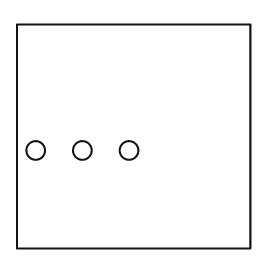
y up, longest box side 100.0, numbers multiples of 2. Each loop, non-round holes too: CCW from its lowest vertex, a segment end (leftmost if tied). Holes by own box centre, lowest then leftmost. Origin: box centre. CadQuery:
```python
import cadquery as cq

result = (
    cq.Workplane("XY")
    .moveTo(-50.0, -48.0)
    .lineTo(50.0, -48.0)
    .lineTo(50.0, 48.0)
    .lineTo(-50.0, 48.0)
    .close()
    .moveTo(-42.0, -6.0)
    .circle(4.0)
    .moveTo(-22.0, -6.0)
    .circle(4.0)
    .moveTo(-2.0, -6.0)
    .circle(4.0)
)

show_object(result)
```